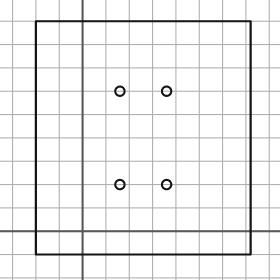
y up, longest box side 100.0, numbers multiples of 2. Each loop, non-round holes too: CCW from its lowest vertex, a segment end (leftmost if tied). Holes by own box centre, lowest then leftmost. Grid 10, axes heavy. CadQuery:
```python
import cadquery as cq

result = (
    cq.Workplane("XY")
    .moveTo(-20.0, -10.0)
    .lineTo(72.0, -10.0)
    .lineTo(72.0, 90.0)
    .lineTo(-20.0, 90.0)
    .close()
    .moveTo(16.0, 20.0)
    .circle(2.0)
    .moveTo(36.0, 20.0)
    .circle(2.0)
    .moveTo(16.0, 60.0)
    .circle(2.0)
    .moveTo(36.0, 60.0)
    .circle(2.0)
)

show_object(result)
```